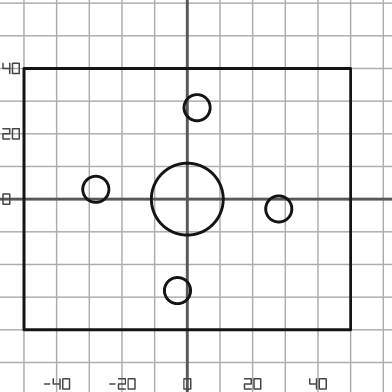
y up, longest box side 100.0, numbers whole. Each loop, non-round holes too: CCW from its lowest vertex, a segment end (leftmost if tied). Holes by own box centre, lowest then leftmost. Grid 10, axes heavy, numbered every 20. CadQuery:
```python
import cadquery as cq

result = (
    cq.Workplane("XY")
    .moveTo(-50.0, -40.0)
    .lineTo(50.0, -40.0)
    .lineTo(50.0, 40.0)
    .lineTo(-50.0, 40.0)
    .close()
    .moveTo(-3.0, -28.0)
    .circle(4.0)
    .moveTo(28.0, -3.0)
    .circle(4.0)
    .moveTo(0.0, 0.0)
    .circle(11.0)
    .moveTo(-28.0, 3.0)
    .circle(4.0)
    .moveTo(3.0, 28.0)
    .circle(4.0)
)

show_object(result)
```